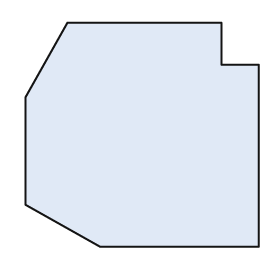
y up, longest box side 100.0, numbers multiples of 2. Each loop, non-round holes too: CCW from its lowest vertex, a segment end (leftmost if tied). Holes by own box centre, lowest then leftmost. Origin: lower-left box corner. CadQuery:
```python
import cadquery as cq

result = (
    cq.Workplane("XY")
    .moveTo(32.0, 0.0)
    .lineTo(100.0, 0.0)
    .lineTo(100.0, 78.0)
    .lineTo(84.0, 78.0)
    .lineTo(84.0, 96.0)
    .lineTo(18.0, 96.0)
    .lineTo(0.0, 64.0)
    .lineTo(0.0, 18.0)
    .close()
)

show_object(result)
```